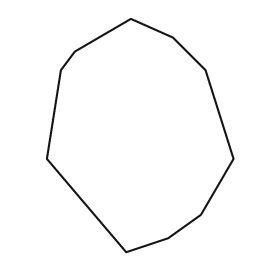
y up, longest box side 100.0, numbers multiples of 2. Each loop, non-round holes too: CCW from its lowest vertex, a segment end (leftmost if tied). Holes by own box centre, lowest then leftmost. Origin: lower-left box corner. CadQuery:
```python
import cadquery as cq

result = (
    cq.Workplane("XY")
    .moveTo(34.0, 0.0)
    .lineTo(52.0, 6.0)
    .lineTo(66.0, 16.0)
    .lineTo(80.0, 40.0)
    .lineTo(68.0, 78.0)
    .lineTo(54.0, 92.0)
    .lineTo(36.0, 100.0)
    .lineTo(12.0, 86.0)
    .lineTo(6.0, 78.0)
    .lineTo(0.0, 40.0)
    .close()
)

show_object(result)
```